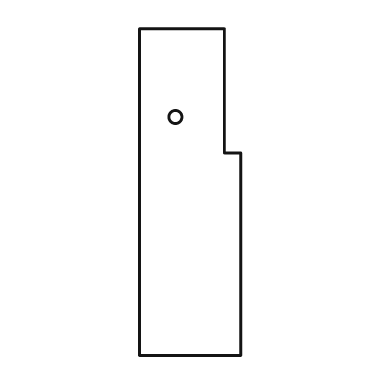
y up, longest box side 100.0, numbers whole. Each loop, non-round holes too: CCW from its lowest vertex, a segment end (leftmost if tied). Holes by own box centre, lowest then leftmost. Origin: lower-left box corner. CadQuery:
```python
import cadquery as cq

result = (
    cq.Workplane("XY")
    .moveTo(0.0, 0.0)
    .lineTo(31.0, 0.0)
    .lineTo(31.0, 62.0)
    .lineTo(26.0, 62.0)
    .lineTo(26.0, 100.0)
    .lineTo(0.0, 100.0)
    .close()
    .moveTo(11.0, 73.0)
    .circle(2.0)
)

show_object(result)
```